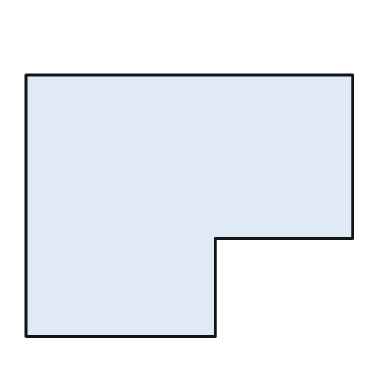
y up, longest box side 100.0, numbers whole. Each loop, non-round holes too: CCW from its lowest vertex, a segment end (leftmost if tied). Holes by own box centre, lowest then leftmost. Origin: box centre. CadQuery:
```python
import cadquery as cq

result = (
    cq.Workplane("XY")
    .moveTo(-50.0, -40.0)
    .lineTo(8.0, -40.0)
    .lineTo(8.0, -10.0)
    .lineTo(50.0, -10.0)
    .lineTo(50.0, 40.0)
    .lineTo(-50.0, 40.0)
    .close()
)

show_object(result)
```